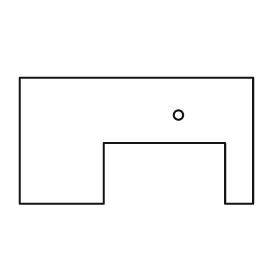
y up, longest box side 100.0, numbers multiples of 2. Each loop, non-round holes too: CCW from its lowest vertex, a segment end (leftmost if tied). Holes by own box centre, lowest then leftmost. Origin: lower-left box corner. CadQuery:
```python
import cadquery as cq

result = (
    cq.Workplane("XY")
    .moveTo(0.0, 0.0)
    .lineTo(36.0, 0.0)
    .lineTo(36.0, 26.0)
    .lineTo(88.0, 26.0)
    .lineTo(88.0, 0.0)
    .lineTo(100.0, 0.0)
    .lineTo(100.0, 54.0)
    .lineTo(0.0, 54.0)
    .close()
    .moveTo(68.0, 38.0)
    .circle(2.0)
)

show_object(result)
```